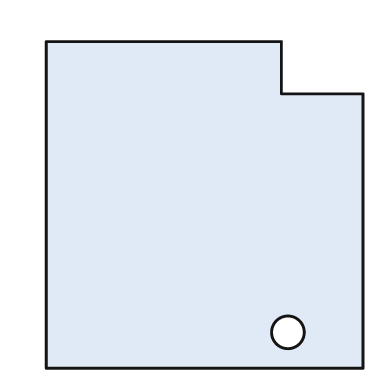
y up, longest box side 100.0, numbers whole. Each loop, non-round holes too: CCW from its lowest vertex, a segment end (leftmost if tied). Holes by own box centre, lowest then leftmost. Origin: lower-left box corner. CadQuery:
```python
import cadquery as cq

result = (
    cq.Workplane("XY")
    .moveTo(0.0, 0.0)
    .lineTo(97.0, 0.0)
    .lineTo(97.0, 84.0)
    .lineTo(72.0, 84.0)
    .lineTo(72.0, 100.0)
    .lineTo(0.0, 100.0)
    .close()
    .moveTo(74.0, 11.0)
    .circle(5.0)
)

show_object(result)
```